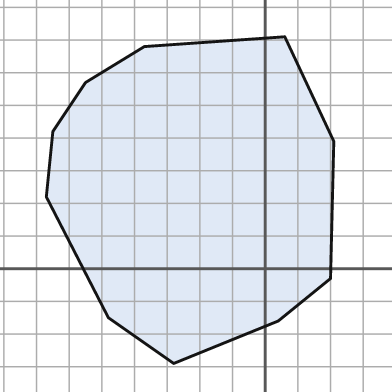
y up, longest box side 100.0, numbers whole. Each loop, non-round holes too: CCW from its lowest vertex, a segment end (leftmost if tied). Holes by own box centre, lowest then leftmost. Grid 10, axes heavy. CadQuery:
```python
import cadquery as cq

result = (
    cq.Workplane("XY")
    .moveTo(-28.0, -29.0)
    .lineTo(4.0, -16.0)
    .lineTo(20.0, -3.0)
    .lineTo(21.0, 39.0)
    .lineTo(6.0, 71.0)
    .lineTo(-37.0, 68.0)
    .lineTo(-55.0, 57.0)
    .lineTo(-65.0, 42.0)
    .lineTo(-67.0, 22.0)
    .lineTo(-48.0, -15.0)
    .close()
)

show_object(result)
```